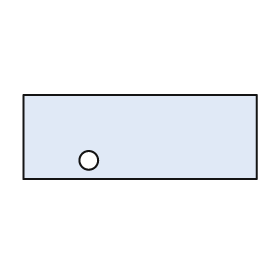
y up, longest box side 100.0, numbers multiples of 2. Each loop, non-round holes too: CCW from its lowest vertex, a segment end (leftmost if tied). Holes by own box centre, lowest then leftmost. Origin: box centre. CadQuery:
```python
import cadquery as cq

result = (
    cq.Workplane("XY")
    .moveTo(-50.0, -18.0)
    .lineTo(50.0, -18.0)
    .lineTo(50.0, 18.0)
    .lineTo(-50.0, 18.0)
    .close()
    .moveTo(-22.0, -10.0)
    .circle(4.0)
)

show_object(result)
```